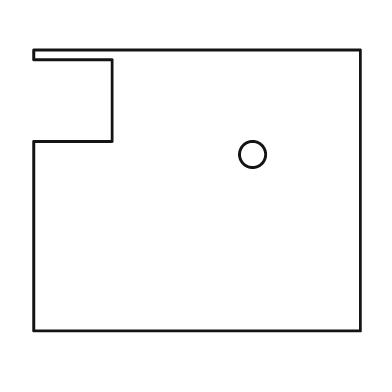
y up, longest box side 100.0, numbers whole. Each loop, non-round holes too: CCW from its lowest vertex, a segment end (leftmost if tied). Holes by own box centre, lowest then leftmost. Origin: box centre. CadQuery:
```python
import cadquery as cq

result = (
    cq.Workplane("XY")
    .moveTo(-50.0, -43.0)
    .lineTo(50.0, -43.0)
    .lineTo(50.0, 43.0)
    .lineTo(-50.0, 43.0)
    .lineTo(-50.0, 40.0)
    .lineTo(-26.0, 40.0)
    .lineTo(-26.0, 15.0)
    .lineTo(-50.0, 15.0)
    .close()
    .moveTo(17.0, 11.0)
    .circle(4.0)
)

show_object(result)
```